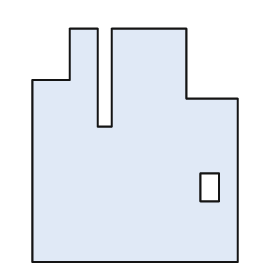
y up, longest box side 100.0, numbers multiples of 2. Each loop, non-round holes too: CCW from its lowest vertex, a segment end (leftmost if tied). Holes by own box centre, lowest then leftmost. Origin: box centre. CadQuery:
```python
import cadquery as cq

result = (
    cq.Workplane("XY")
    .moveTo(-44.0, -50.0)
    .lineTo(44.0, -50.0)
    .lineTo(44.0, 20.0)
    .lineTo(22.0, 20.0)
    .lineTo(22.0, 50.0)
    .lineTo(-10.0, 50.0)
    .lineTo(-10.0, 8.0)
    .lineTo(-16.0, 8.0)
    .lineTo(-16.0, 50.0)
    .lineTo(-28.0, 50.0)
    .lineTo(-28.0, 28.0)
    .lineTo(-44.0, 28.0)
    .close()
    .moveTo(28.0, -24.0)
    .lineTo(36.0, -24.0)
    .lineTo(36.0, -12.0)
    .lineTo(28.0, -12.0)
    .close()
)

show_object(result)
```